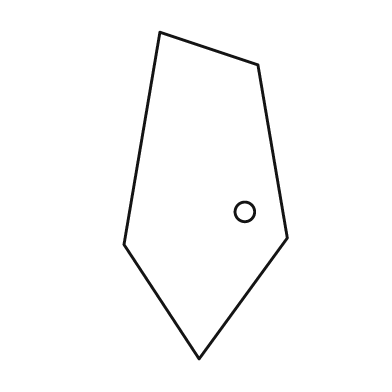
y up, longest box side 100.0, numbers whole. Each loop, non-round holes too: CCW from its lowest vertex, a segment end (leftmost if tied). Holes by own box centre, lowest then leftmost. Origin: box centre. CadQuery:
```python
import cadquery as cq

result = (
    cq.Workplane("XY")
    .moveTo(-2.0, -50.0)
    .lineTo(25.0, -13.0)
    .lineTo(16.0, 40.0)
    .lineTo(-14.0, 50.0)
    .lineTo(-25.0, -15.0)
    .close()
    .moveTo(12.0, -5.0)
    .circle(3.0)
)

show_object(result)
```